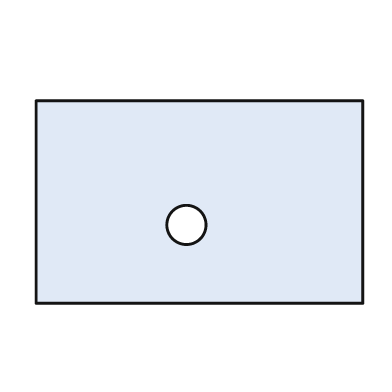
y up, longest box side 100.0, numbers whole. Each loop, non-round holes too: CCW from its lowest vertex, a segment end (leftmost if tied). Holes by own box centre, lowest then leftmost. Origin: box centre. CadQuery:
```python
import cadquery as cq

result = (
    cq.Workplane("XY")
    .moveTo(-50.0, -31.0)
    .lineTo(50.0, -31.0)
    .lineTo(50.0, 31.0)
    .lineTo(-50.0, 31.0)
    .close()
    .moveTo(-4.0, -7.0)
    .circle(6.0)
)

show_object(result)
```